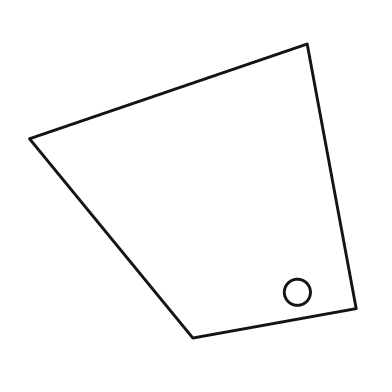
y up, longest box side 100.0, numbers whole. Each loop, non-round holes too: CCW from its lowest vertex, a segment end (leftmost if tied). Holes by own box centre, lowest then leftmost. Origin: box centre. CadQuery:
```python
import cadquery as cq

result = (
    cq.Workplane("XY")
    .moveTo(0.0, -45.0)
    .lineTo(50.0, -36.0)
    .lineTo(35.0, 45.0)
    .lineTo(-50.0, 16.0)
    .close()
    .moveTo(32.0, -31.0)
    .circle(4.0)
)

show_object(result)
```